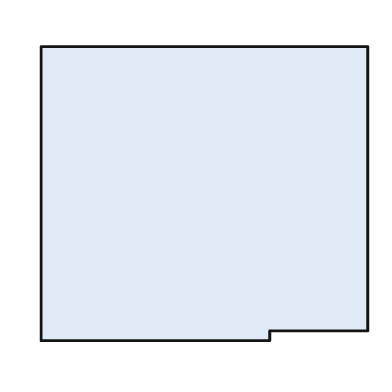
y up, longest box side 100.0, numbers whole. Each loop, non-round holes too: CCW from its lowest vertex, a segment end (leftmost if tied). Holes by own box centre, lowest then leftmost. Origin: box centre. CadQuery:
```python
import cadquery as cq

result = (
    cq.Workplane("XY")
    .moveTo(-50.0, -45.0)
    .lineTo(20.0, -45.0)
    .lineTo(20.0, -42.0)
    .lineTo(50.0, -42.0)
    .lineTo(50.0, 45.0)
    .lineTo(-50.0, 45.0)
    .close()
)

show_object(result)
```